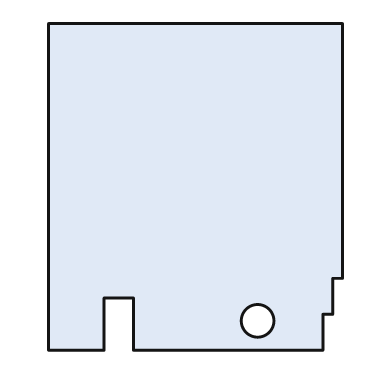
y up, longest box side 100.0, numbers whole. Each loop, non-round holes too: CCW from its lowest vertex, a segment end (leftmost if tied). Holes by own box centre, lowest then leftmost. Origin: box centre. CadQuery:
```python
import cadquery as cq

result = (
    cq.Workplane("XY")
    .moveTo(-45.0, -50.0)
    .lineTo(-28.0, -50.0)
    .lineTo(-28.0, -34.0)
    .lineTo(-19.0, -34.0)
    .lineTo(-19.0, -50.0)
    .lineTo(39.0, -50.0)
    .lineTo(39.0, -39.0)
    .lineTo(42.0, -39.0)
    .lineTo(42.0, -28.0)
    .lineTo(45.0, -28.0)
    .lineTo(45.0, 50.0)
    .lineTo(-45.0, 50.0)
    .close()
    .moveTo(19.0, -41.0)
    .circle(5.0)
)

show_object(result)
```